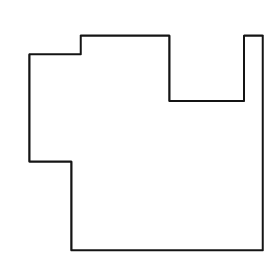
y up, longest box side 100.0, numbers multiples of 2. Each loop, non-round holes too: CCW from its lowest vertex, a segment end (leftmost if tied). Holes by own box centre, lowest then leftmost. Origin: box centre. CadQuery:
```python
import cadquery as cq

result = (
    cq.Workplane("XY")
    .moveTo(-32.0, -46.0)
    .lineTo(50.0, -46.0)
    .lineTo(50.0, 46.0)
    .lineTo(42.0, 46.0)
    .lineTo(42.0, 18.0)
    .lineTo(10.0, 18.0)
    .lineTo(10.0, 46.0)
    .lineTo(-28.0, 46.0)
    .lineTo(-28.0, 38.0)
    .lineTo(-50.0, 38.0)
    .lineTo(-50.0, -8.0)
    .lineTo(-32.0, -8.0)
    .close()
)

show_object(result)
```